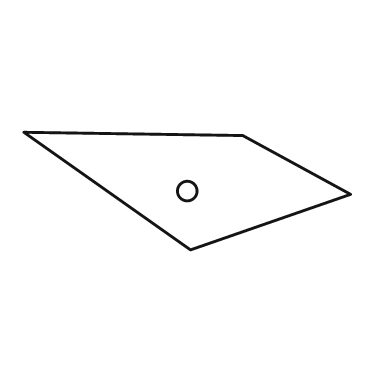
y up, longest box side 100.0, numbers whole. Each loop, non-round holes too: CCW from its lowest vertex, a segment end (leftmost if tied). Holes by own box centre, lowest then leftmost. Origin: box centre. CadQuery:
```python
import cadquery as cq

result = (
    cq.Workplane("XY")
    .moveTo(1.0, -18.0)
    .lineTo(50.0, -1.0)
    .lineTo(17.0, 17.0)
    .lineTo(-50.0, 18.0)
    .close()
    .moveTo(0.0, 0.0)
    .circle(3.0)
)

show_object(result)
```